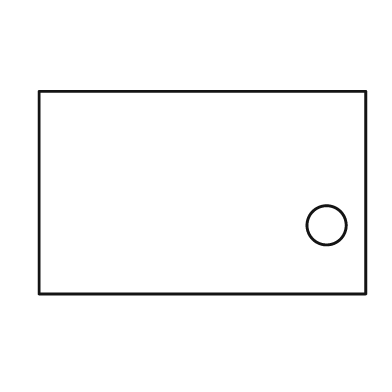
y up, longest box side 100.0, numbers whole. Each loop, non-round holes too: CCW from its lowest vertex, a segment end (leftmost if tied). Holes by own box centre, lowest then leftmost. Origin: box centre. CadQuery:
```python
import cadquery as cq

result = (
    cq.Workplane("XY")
    .moveTo(-50.0, -31.0)
    .lineTo(50.0, -31.0)
    .lineTo(50.0, 31.0)
    .lineTo(-50.0, 31.0)
    .close()
    .moveTo(38.0, -10.0)
    .circle(6.0)
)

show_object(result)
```